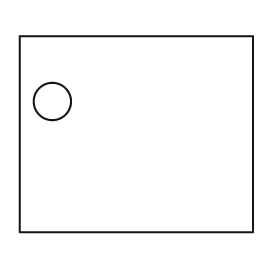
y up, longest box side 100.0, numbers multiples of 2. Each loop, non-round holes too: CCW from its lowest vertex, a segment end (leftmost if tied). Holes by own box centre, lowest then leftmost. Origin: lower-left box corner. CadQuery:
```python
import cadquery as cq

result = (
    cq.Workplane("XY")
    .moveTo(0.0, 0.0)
    .lineTo(100.0, 0.0)
    .lineTo(100.0, 84.0)
    .lineTo(0.0, 84.0)
    .close()
    .moveTo(14.0, 56.0)
    .circle(8.0)
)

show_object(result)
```